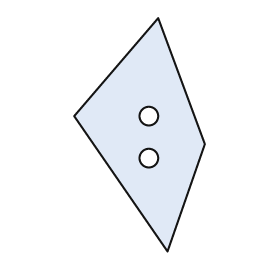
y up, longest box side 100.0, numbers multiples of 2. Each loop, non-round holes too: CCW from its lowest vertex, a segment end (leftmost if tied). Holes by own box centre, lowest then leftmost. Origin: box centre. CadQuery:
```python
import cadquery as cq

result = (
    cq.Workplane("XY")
    .moveTo(12.0, -50.0)
    .lineTo(28.0, -4.0)
    .lineTo(8.0, 50.0)
    .lineTo(-28.0, 8.0)
    .close()
    .moveTo(4.0, -10.0)
    .circle(4.0)
    .moveTo(4.0, 8.0)
    .circle(4.0)
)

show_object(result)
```